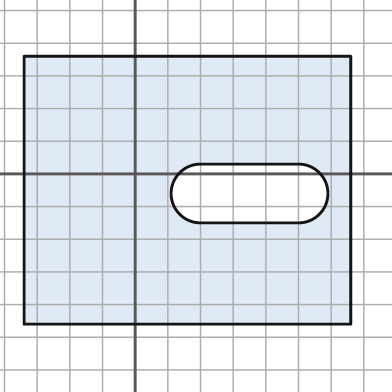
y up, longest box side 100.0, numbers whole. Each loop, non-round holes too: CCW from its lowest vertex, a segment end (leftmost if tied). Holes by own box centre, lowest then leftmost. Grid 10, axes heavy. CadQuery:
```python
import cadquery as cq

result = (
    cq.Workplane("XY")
    .moveTo(-34.0, -46.0)
    .lineTo(66.0, -46.0)
    .lineTo(66.0, 36.0)
    .lineTo(-34.0, 36.0)
    .close()
    .moveTo(20.0, -15.0)
    .lineTo(50.0, -15.0)
    .threePointArc((59.0, -6.0), (50.0, 3.0))
    .lineTo(20.0, 3.0)
    .threePointArc((11.0, -6.0), (20.0, -15.0))
    .close()
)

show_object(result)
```